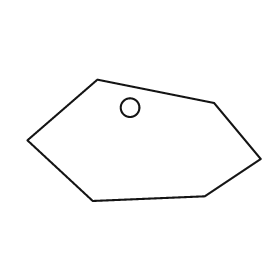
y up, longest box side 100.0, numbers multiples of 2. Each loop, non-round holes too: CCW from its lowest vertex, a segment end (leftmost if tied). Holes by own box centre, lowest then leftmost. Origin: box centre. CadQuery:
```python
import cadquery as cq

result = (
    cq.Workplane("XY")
    .moveTo(-22.0, -26.0)
    .lineTo(26.0, -24.0)
    .lineTo(50.0, -8.0)
    .lineTo(30.0, 16.0)
    .lineTo(-20.0, 26.0)
    .lineTo(-50.0, 0.0)
    .close()
    .moveTo(-6.0, 14.0)
    .circle(4.0)
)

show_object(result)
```